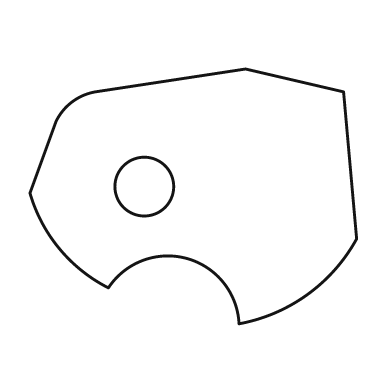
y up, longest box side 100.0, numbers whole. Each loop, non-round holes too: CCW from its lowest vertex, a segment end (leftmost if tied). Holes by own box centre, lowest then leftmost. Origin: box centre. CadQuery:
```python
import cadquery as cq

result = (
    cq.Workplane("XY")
    .moveTo(14.0, -39.0)
    .threePointArc((35.0, -30.0), (50.0, -13.0))
    .lineTo(46.0, 32.0)
    .lineTo(16.0, 39.0)
    .lineTo(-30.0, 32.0)
    .threePointArc((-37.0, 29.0), (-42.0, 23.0))
    .lineTo(-50.0, 1.0)
    .threePointArc((-41.0, -16.0), (-26.0, -28.0))
    .threePointArc((-2.0, -19.0), (14.0, -39.0))
    .close()
    .moveTo(-15.0, 3.0)
    .circle(9.0)
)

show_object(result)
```